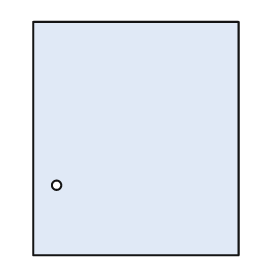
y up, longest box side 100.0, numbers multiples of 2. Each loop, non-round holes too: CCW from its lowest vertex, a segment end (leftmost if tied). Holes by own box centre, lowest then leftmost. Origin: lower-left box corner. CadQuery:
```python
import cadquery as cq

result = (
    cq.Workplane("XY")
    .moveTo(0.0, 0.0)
    .lineTo(88.0, 0.0)
    .lineTo(88.0, 100.0)
    .lineTo(0.0, 100.0)
    .close()
    .moveTo(10.0, 30.0)
    .circle(2.0)
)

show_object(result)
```